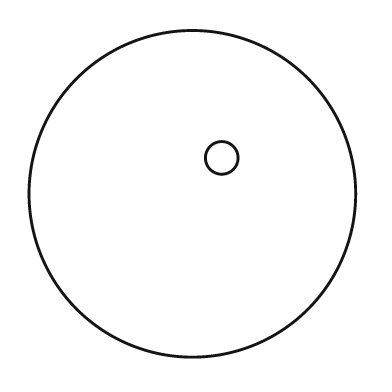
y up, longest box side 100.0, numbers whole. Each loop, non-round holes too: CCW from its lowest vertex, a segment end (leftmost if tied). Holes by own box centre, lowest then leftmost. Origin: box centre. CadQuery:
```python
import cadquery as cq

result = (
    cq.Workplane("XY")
    .moveTo(0.0, 0.0)
    .circle(50.0)
    .moveTo(9.0, 11.0)
    .circle(5.0)
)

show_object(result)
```